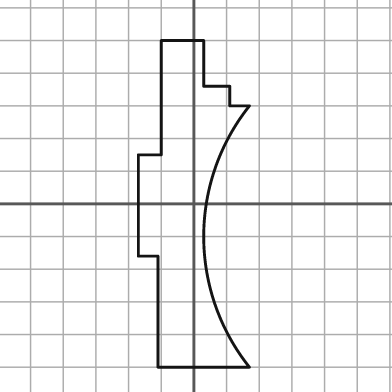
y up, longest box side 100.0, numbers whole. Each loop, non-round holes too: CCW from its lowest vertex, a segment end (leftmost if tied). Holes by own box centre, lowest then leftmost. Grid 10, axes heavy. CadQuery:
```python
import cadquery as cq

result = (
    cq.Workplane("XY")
    .moveTo(-11.0, -50.0)
    .lineTo(17.0, -50.0)
    .threePointArc((3.0, -10.0), (17.0, 30.0))
    .lineTo(11.0, 30.0)
    .lineTo(11.0, 36.0)
    .lineTo(3.0, 36.0)
    .lineTo(3.0, 50.0)
    .lineTo(-10.0, 50.0)
    .lineTo(-10.0, 15.0)
    .lineTo(-17.0, 15.0)
    .lineTo(-17.0, -16.0)
    .lineTo(-11.0, -16.0)
    .close()
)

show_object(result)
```